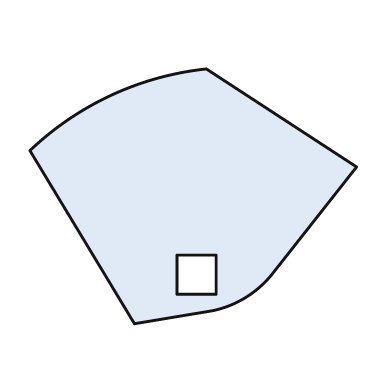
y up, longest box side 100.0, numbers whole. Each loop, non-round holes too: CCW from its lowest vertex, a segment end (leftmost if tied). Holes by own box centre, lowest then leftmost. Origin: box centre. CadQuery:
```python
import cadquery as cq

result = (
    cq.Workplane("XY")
    .moveTo(-18.0, -39.0)
    .lineTo(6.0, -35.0)
    .threePointArc((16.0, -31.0), (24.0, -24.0))
    .lineTo(50.0, 9.0)
    .lineTo(4.0, 39.0)
    .threePointArc((-25.0, 31.0), (-50.0, 14.0))
    .close()
    .moveTo(-5.0, -30.0)
    .lineTo(7.0, -30.0)
    .lineTo(7.0, -18.0)
    .lineTo(-5.0, -18.0)
    .close()
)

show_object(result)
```